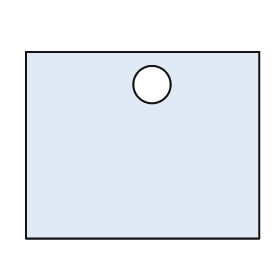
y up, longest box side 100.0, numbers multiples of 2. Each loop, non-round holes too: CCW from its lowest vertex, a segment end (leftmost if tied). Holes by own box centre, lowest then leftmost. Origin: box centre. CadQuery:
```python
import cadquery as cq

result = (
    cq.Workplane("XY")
    .moveTo(-50.0, -40.0)
    .lineTo(50.0, -40.0)
    .lineTo(50.0, 40.0)
    .lineTo(-50.0, 40.0)
    .close()
    .moveTo(4.0, 26.0)
    .circle(8.0)
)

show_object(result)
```